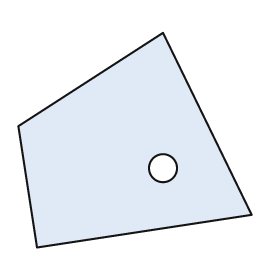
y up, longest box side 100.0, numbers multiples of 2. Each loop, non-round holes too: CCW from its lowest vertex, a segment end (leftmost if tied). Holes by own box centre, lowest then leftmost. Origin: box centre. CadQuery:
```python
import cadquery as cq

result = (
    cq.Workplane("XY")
    .moveTo(-42.0, -46.0)
    .lineTo(50.0, -32.0)
    .lineTo(12.0, 46.0)
    .lineTo(-50.0, 6.0)
    .close()
    .moveTo(12.0, -12.0)
    .circle(6.0)
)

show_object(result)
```